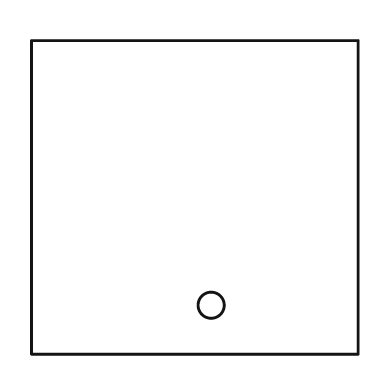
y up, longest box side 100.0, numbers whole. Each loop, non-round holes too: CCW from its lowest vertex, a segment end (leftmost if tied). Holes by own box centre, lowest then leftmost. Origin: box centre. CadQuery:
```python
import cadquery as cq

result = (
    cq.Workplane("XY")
    .moveTo(-50.0, -48.0)
    .lineTo(50.0, -48.0)
    .lineTo(50.0, 48.0)
    .lineTo(-50.0, 48.0)
    .close()
    .moveTo(5.0, -33.0)
    .circle(4.0)
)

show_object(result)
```